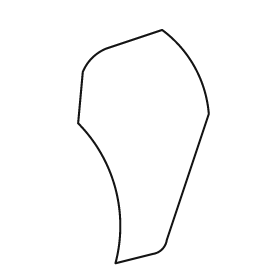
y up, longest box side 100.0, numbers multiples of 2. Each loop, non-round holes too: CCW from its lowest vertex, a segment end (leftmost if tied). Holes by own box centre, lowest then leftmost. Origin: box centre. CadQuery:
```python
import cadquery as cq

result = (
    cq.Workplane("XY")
    .moveTo(-12.0, -50.0)
    .lineTo(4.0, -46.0)
    .threePointArc((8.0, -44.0), (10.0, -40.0))
    .lineTo(28.0, 14.0)
    .threePointArc((22.0, 34.0), (8.0, 50.0))
    .lineTo(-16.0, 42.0)
    .threePointArc((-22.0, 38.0), (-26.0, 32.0))
    .lineTo(-28.0, 10.0)
    .threePointArc((-12.0, -18.0), (-12.0, -50.0))
    .close()
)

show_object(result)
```